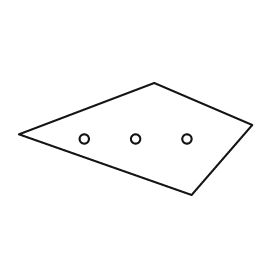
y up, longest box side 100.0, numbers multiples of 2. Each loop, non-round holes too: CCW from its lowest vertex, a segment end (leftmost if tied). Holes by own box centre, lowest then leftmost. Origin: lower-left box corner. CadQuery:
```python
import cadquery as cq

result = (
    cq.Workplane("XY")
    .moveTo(74.0, 0.0)
    .lineTo(100.0, 30.0)
    .lineTo(58.0, 48.0)
    .lineTo(0.0, 26.0)
    .close()
    .moveTo(28.0, 24.0)
    .circle(2.0)
    .moveTo(50.0, 24.0)
    .circle(2.0)
    .moveTo(72.0, 24.0)
    .circle(2.0)
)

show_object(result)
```